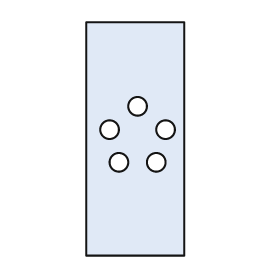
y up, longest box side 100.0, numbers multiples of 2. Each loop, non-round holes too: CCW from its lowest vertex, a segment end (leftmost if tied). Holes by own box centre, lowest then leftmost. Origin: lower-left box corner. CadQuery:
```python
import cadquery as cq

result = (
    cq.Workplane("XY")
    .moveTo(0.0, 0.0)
    .lineTo(42.0, 0.0)
    .lineTo(42.0, 100.0)
    .lineTo(0.0, 100.0)
    .close()
    .moveTo(14.0, 40.0)
    .circle(4.0)
    .moveTo(30.0, 40.0)
    .circle(4.0)
    .moveTo(10.0, 54.0)
    .circle(4.0)
    .moveTo(34.0, 54.0)
    .circle(4.0)
    .moveTo(22.0, 64.0)
    .circle(4.0)
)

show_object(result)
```